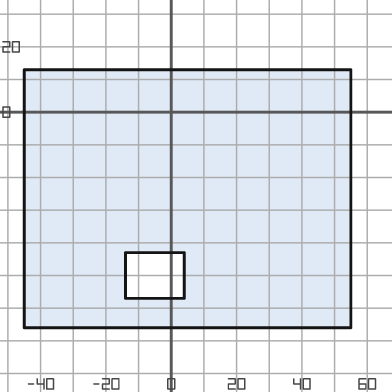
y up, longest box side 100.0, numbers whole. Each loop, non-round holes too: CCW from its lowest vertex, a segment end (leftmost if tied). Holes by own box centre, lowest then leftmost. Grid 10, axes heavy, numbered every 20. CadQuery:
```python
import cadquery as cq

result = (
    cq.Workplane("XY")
    .moveTo(-45.0, -66.0)
    .lineTo(55.0, -66.0)
    .lineTo(55.0, 13.0)
    .lineTo(-45.0, 13.0)
    .close()
    .moveTo(-14.0, -57.0)
    .lineTo(4.0, -57.0)
    .lineTo(4.0, -43.0)
    .lineTo(-14.0, -43.0)
    .close()
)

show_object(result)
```